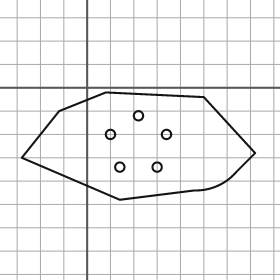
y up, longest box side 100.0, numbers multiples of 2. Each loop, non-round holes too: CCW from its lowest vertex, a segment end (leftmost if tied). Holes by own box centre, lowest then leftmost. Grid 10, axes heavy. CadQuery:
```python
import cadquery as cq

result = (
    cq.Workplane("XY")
    .moveTo(14.0, -48.0)
    .lineTo(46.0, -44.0)
    .threePointArc((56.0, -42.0), (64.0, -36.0))
    .lineTo(72.0, -28.0)
    .lineTo(50.0, -4.0)
    .lineTo(8.0, -2.0)
    .lineTo(-12.0, -10.0)
    .lineTo(-28.0, -30.0)
    .close()
    .moveTo(14.0, -34.0)
    .circle(2.0)
    .moveTo(30.0, -34.0)
    .circle(2.0)
    .moveTo(10.0, -20.0)
    .circle(2.0)
    .moveTo(34.0, -20.0)
    .circle(2.0)
    .moveTo(22.0, -12.0)
    .circle(2.0)
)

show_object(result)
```